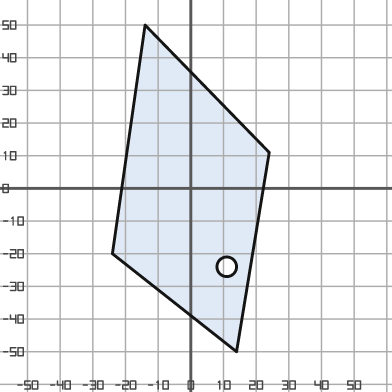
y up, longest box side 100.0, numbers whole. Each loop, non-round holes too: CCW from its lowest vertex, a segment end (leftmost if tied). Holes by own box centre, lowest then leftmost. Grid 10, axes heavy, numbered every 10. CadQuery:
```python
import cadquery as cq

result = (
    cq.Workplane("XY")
    .moveTo(14.0, -50.0)
    .lineTo(24.0, 11.0)
    .lineTo(-14.0, 50.0)
    .lineTo(-24.0, -20.0)
    .close()
    .moveTo(11.0, -24.0)
    .circle(3.0)
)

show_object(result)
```